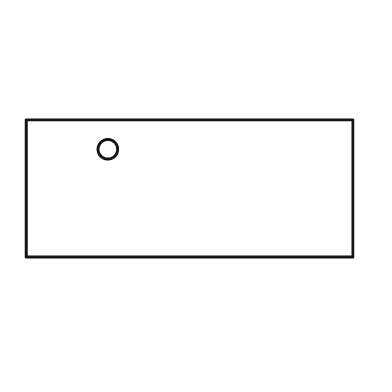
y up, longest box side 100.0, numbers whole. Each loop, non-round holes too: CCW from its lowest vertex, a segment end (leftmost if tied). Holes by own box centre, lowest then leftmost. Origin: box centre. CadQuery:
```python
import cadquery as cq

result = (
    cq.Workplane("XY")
    .moveTo(-50.0, -21.0)
    .lineTo(50.0, -21.0)
    .lineTo(50.0, 21.0)
    .lineTo(-50.0, 21.0)
    .close()
    .moveTo(-25.0, 12.0)
    .circle(3.0)
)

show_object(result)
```